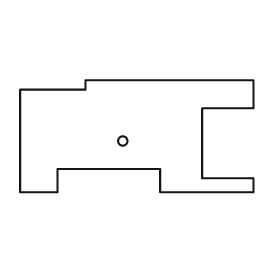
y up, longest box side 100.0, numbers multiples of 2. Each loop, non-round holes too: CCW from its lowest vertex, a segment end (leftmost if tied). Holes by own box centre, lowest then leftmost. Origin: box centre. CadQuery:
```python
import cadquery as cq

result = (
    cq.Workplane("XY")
    .moveTo(-50.0, -24.0)
    .lineTo(-34.0, -24.0)
    .lineTo(-34.0, -14.0)
    .lineTo(10.0, -14.0)
    .lineTo(10.0, -24.0)
    .lineTo(50.0, -24.0)
    .lineTo(50.0, -18.0)
    .lineTo(28.0, -18.0)
    .lineTo(28.0, 12.0)
    .lineTo(50.0, 12.0)
    .lineTo(50.0, 24.0)
    .lineTo(-22.0, 24.0)
    .lineTo(-22.0, 20.0)
    .lineTo(-50.0, 20.0)
    .close()
    .moveTo(-6.0, -2.0)
    .circle(2.0)
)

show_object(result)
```